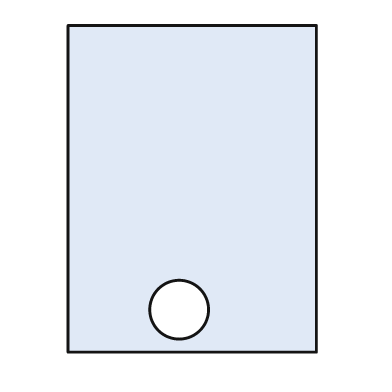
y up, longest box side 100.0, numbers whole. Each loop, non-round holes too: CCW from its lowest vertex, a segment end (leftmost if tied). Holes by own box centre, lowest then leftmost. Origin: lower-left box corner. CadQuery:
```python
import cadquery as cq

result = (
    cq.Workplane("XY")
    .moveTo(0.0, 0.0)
    .lineTo(76.0, 0.0)
    .lineTo(76.0, 100.0)
    .lineTo(0.0, 100.0)
    .close()
    .moveTo(34.0, 13.0)
    .circle(9.0)
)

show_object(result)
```